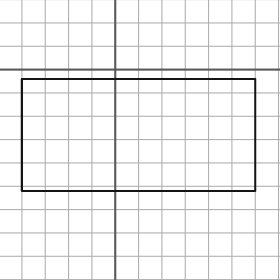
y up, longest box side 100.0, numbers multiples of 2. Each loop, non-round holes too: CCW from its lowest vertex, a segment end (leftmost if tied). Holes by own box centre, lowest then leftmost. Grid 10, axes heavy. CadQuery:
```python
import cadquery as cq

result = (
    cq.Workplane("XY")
    .moveTo(-40.0, -52.0)
    .lineTo(60.0, -52.0)
    .lineTo(60.0, -4.0)
    .lineTo(-40.0, -4.0)
    .close()
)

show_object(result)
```